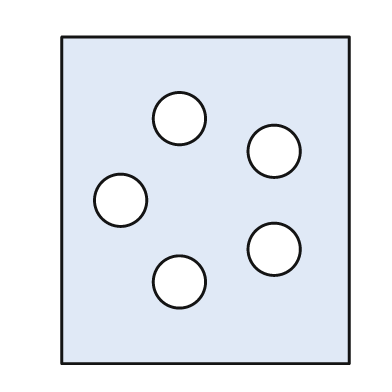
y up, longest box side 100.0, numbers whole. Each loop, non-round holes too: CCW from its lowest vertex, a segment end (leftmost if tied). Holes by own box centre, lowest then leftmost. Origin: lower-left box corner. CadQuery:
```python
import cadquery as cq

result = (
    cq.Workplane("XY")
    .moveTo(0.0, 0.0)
    .lineTo(88.0, 0.0)
    .lineTo(88.0, 100.0)
    .lineTo(0.0, 100.0)
    .close()
    .moveTo(36.0, 25.0)
    .circle(8.0)
    .moveTo(65.0, 35.0)
    .circle(8.0)
    .moveTo(18.0, 50.0)
    .circle(8.0)
    .moveTo(65.0, 65.0)
    .circle(8.0)
    .moveTo(36.0, 75.0)
    .circle(8.0)
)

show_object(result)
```